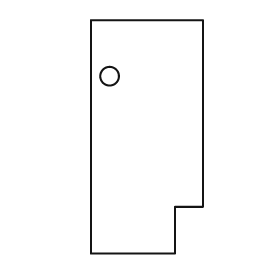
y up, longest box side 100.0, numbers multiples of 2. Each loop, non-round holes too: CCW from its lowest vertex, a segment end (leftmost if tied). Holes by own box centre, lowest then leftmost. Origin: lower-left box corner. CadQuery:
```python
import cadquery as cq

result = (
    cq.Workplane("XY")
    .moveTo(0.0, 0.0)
    .lineTo(36.0, 0.0)
    .lineTo(36.0, 20.0)
    .lineTo(48.0, 20.0)
    .lineTo(48.0, 100.0)
    .lineTo(0.0, 100.0)
    .close()
    .moveTo(8.0, 76.0)
    .circle(4.0)
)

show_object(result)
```